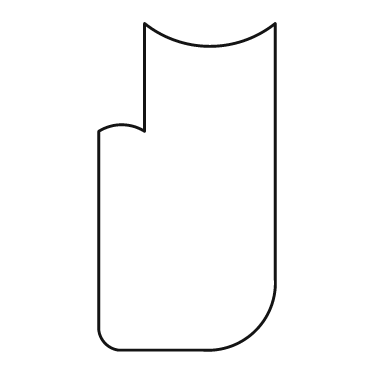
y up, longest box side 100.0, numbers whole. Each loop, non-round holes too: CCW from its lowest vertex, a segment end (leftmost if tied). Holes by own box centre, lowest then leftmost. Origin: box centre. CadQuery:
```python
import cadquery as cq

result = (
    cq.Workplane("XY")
    .moveTo(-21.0, -50.0)
    .lineTo(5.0, -50.0)
    .threePointArc((21.0, -44.0), (27.0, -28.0))
    .lineTo(27.0, 50.0)
    .threePointArc((7.0, 43.0), (-13.0, 50.0))
    .lineTo(-13.0, 17.0)
    .threePointArc((-20.0, 19.0), (-27.0, 17.0))
    .lineTo(-27.0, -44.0)
    .threePointArc((-25.0, -48.0), (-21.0, -50.0))
    .close()
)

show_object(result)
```